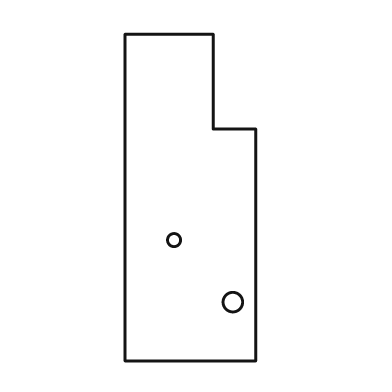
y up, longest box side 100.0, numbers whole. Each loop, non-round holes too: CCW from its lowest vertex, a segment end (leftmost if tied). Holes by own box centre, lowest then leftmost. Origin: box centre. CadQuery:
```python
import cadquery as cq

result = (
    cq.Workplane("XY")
    .moveTo(-20.0, -50.0)
    .lineTo(20.0, -50.0)
    .lineTo(20.0, 21.0)
    .lineTo(7.0, 21.0)
    .lineTo(7.0, 50.0)
    .lineTo(-20.0, 50.0)
    .close()
    .moveTo(13.0, -32.0)
    .circle(3.0)
    .moveTo(-5.0, -13.0)
    .circle(2.0)
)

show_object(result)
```